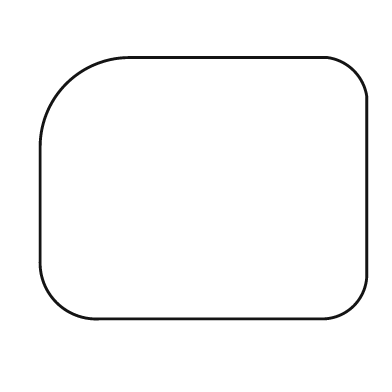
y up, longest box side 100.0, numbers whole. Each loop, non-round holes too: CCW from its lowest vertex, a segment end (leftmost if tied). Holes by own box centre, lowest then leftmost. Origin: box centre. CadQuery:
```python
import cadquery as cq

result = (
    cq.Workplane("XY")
    .moveTo(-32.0, -40.0)
    .lineTo(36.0, -40.0)
    .threePointArc((46.0, -36.0), (50.0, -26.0))
    .lineTo(50.0, 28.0)
    .threePointArc((46.0, 36.0), (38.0, 40.0))
    .lineTo(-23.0, 40.0)
    .threePointArc((-42.0, 32.0), (-50.0, 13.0))
    .lineTo(-50.0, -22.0)
    .threePointArc((-45.0, -35.0), (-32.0, -40.0))
    .close()
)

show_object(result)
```